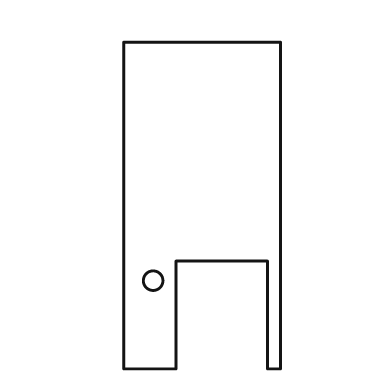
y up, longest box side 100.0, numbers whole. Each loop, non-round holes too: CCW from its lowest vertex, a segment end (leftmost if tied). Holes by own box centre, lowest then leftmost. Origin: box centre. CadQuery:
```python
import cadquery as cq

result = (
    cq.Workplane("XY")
    .moveTo(-24.0, -50.0)
    .lineTo(-8.0, -50.0)
    .lineTo(-8.0, -17.0)
    .lineTo(20.0, -17.0)
    .lineTo(20.0, -50.0)
    .lineTo(24.0, -50.0)
    .lineTo(24.0, 50.0)
    .lineTo(-24.0, 50.0)
    .close()
    .moveTo(-15.0, -23.0)
    .circle(3.0)
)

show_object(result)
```